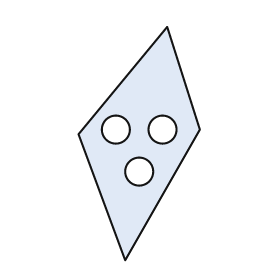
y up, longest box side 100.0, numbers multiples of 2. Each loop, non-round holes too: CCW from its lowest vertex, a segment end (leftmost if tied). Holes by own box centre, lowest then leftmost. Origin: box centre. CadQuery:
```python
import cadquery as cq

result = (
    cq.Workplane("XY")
    .moveTo(-6.0, -50.0)
    .lineTo(26.0, 6.0)
    .lineTo(12.0, 50.0)
    .lineTo(-26.0, 4.0)
    .close()
    .moveTo(0.0, -12.0)
    .circle(6.0)
    .moveTo(-10.0, 6.0)
    .circle(6.0)
    .moveTo(10.0, 6.0)
    .circle(6.0)
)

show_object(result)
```